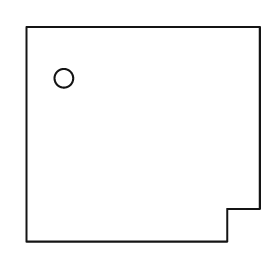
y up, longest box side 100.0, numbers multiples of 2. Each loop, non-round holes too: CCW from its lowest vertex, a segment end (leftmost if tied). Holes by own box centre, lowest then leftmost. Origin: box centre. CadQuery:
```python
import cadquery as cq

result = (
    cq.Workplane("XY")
    .moveTo(-50.0, -46.0)
    .lineTo(36.0, -46.0)
    .lineTo(36.0, -32.0)
    .lineTo(50.0, -32.0)
    .lineTo(50.0, 46.0)
    .lineTo(-50.0, 46.0)
    .close()
    .moveTo(-34.0, 24.0)
    .circle(4.0)
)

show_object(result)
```